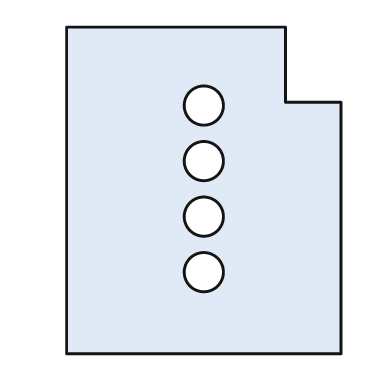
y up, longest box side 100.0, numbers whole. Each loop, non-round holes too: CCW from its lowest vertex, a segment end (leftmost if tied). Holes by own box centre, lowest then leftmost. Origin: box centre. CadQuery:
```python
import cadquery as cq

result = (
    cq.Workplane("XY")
    .moveTo(-42.0, -50.0)
    .lineTo(42.0, -50.0)
    .lineTo(42.0, 27.0)
    .lineTo(25.0, 27.0)
    .lineTo(25.0, 50.0)
    .lineTo(-42.0, 50.0)
    .close()
    .moveTo(0.0, -25.0)
    .circle(6.0)
    .moveTo(0.0, -8.0)
    .circle(6.0)
    .moveTo(0.0, 9.0)
    .circle(6.0)
    .moveTo(0.0, 26.0)
    .circle(6.0)
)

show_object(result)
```